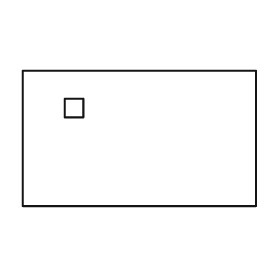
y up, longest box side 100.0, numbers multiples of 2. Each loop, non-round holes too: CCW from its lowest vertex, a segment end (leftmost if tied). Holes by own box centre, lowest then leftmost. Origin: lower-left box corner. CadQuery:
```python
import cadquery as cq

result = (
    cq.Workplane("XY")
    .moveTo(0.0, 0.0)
    .lineTo(100.0, 0.0)
    .lineTo(100.0, 58.0)
    .lineTo(0.0, 58.0)
    .close()
    .moveTo(18.0, 38.0)
    .lineTo(26.0, 38.0)
    .lineTo(26.0, 46.0)
    .lineTo(18.0, 46.0)
    .close()
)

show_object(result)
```